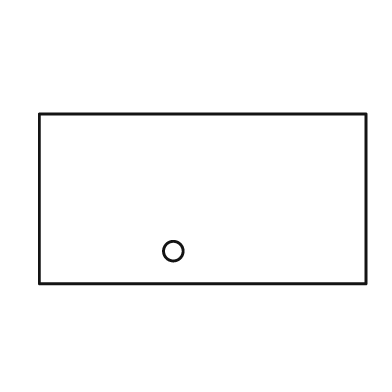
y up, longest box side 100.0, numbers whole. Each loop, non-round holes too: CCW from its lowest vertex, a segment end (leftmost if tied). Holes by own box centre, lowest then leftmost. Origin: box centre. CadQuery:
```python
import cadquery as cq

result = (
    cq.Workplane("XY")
    .moveTo(-50.0, -26.0)
    .lineTo(50.0, -26.0)
    .lineTo(50.0, 26.0)
    .lineTo(-50.0, 26.0)
    .close()
    .moveTo(-9.0, -16.0)
    .circle(3.0)
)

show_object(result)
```